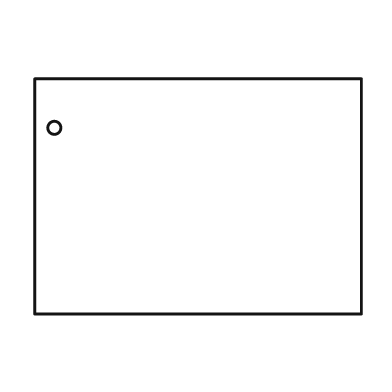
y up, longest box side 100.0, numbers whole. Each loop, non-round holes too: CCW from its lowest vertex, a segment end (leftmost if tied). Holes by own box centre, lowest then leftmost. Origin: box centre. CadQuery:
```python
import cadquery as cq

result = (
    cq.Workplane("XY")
    .moveTo(-50.0, -36.0)
    .lineTo(50.0, -36.0)
    .lineTo(50.0, 36.0)
    .lineTo(-50.0, 36.0)
    .close()
    .moveTo(-44.0, 21.0)
    .circle(2.0)
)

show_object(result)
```